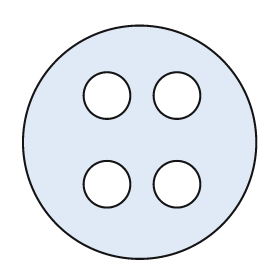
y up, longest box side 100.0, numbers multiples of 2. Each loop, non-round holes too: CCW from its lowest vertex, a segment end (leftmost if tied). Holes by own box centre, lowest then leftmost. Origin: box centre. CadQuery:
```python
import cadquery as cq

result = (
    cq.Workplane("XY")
    .moveTo(0.0, 0.0)
    .circle(50.0)
    .moveTo(-14.0, -18.0)
    .circle(10.0)
    .moveTo(16.0, -18.0)
    .circle(10.0)
    .moveTo(-14.0, 20.0)
    .circle(10.0)
    .moveTo(16.0, 20.0)
    .circle(10.0)
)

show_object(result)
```